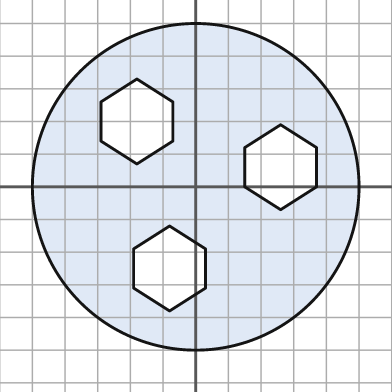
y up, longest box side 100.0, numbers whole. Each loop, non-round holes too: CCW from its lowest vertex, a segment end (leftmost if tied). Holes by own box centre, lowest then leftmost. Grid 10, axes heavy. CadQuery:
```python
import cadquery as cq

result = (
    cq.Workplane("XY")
    .moveTo(0.0, 0.0)
    .circle(50.0)
    .moveTo(-8.0, -38.0)
    .lineTo(3.0, -31.0)
    .lineTo(3.0, -19.0)
    .lineTo(-8.0, -12.0)
    .lineTo(-19.0, -19.0)
    .lineTo(-19.0, -31.0)
    .close()
    .moveTo(26.0, -7.0)
    .lineTo(37.0, 0.0)
    .lineTo(37.0, 12.0)
    .lineTo(26.0, 19.0)
    .lineTo(15.0, 12.0)
    .lineTo(15.0, 0.0)
    .close()
    .moveTo(-18.0, 7.0)
    .lineTo(-7.0, 14.0)
    .lineTo(-7.0, 26.0)
    .lineTo(-18.0, 33.0)
    .lineTo(-29.0, 26.0)
    .lineTo(-29.0, 14.0)
    .close()
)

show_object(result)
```